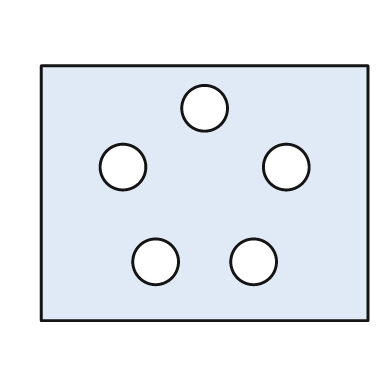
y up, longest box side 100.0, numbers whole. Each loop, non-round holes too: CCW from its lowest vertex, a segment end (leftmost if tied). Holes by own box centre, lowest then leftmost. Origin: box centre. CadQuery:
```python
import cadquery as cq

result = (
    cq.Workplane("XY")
    .moveTo(-50.0, -39.0)
    .lineTo(50.0, -39.0)
    .lineTo(50.0, 39.0)
    .lineTo(-50.0, 39.0)
    .close()
    .moveTo(-15.0, -21.0)
    .circle(7.0)
    .moveTo(15.0, -21.0)
    .circle(7.0)
    .moveTo(-25.0, 8.0)
    .circle(7.0)
    .moveTo(25.0, 8.0)
    .circle(7.0)
    .moveTo(0.0, 26.0)
    .circle(7.0)
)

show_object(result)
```